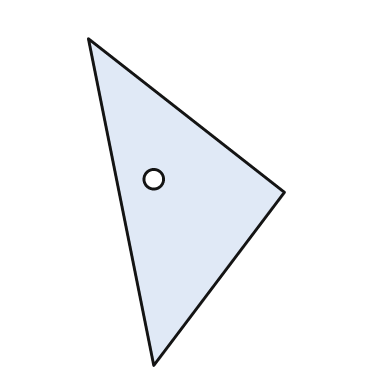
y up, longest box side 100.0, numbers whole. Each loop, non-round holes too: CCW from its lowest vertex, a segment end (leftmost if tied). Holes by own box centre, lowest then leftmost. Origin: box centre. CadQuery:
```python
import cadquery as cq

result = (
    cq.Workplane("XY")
    .moveTo(-10.0, -50.0)
    .lineTo(30.0, 3.0)
    .lineTo(-30.0, 50.0)
    .close()
    .moveTo(-10.0, 7.0)
    .circle(3.0)
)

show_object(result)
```